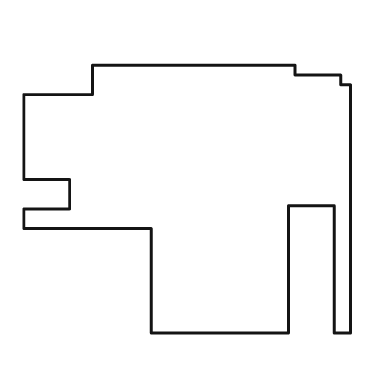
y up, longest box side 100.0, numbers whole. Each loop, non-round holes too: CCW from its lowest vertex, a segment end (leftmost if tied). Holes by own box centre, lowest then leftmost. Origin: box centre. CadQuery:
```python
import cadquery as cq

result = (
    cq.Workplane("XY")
    .moveTo(-11.0, -41.0)
    .lineTo(31.0, -41.0)
    .lineTo(31.0, -2.0)
    .lineTo(45.0, -2.0)
    .lineTo(45.0, -41.0)
    .lineTo(50.0, -41.0)
    .lineTo(50.0, 35.0)
    .lineTo(47.0, 35.0)
    .lineTo(47.0, 38.0)
    .lineTo(33.0, 38.0)
    .lineTo(33.0, 41.0)
    .lineTo(-29.0, 41.0)
    .lineTo(-29.0, 32.0)
    .lineTo(-50.0, 32.0)
    .lineTo(-50.0, 6.0)
    .lineTo(-36.0, 6.0)
    .lineTo(-36.0, -3.0)
    .lineTo(-50.0, -3.0)
    .lineTo(-50.0, -9.0)
    .lineTo(-11.0, -9.0)
    .close()
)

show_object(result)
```